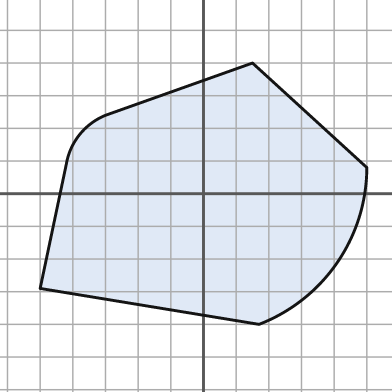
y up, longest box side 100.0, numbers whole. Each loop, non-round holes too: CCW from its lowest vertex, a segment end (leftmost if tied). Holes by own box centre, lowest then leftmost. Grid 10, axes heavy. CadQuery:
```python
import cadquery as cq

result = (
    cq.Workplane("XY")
    .moveTo(17.0, -40.0)
    .threePointArc((41.0, -21.0), (50.0, 8.0))
    .lineTo(15.0, 40.0)
    .lineTo(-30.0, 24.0)
    .threePointArc((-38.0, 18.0), (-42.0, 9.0))
    .lineTo(-50.0, -29.0)
    .close()
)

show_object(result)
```